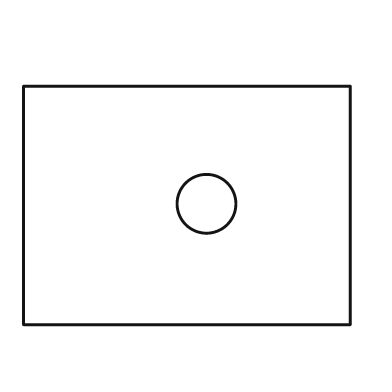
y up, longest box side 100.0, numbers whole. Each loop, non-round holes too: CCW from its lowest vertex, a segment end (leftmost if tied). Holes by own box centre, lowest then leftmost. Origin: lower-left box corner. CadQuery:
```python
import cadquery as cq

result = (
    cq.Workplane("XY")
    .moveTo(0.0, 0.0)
    .lineTo(100.0, 0.0)
    .lineTo(100.0, 73.0)
    .lineTo(0.0, 73.0)
    .close()
    .moveTo(56.0, 37.0)
    .circle(9.0)
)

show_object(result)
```